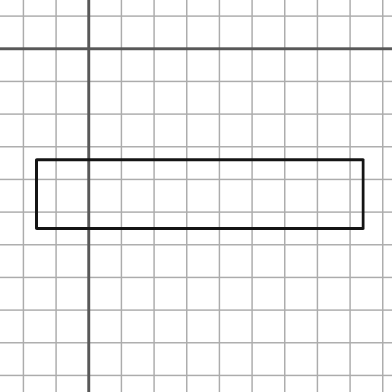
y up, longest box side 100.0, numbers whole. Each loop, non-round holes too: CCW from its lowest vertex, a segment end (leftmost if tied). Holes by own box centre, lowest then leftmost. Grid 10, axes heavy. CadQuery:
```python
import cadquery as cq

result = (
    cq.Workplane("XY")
    .moveTo(-16.0, -55.0)
    .lineTo(84.0, -55.0)
    .lineTo(84.0, -34.0)
    .lineTo(-16.0, -34.0)
    .close()
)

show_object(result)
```